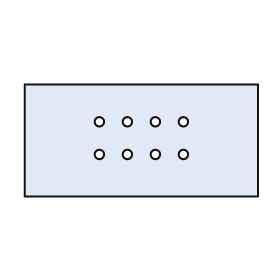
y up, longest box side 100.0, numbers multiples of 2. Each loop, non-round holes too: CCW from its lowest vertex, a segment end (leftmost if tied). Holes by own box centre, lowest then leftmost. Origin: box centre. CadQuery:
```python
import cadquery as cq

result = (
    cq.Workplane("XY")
    .moveTo(-50.0, -24.0)
    .lineTo(50.0, -24.0)
    .lineTo(50.0, 24.0)
    .lineTo(-50.0, 24.0)
    .close()
    .moveTo(-18.0, -6.0)
    .circle(2.0)
    .moveTo(-6.0, -6.0)
    .circle(2.0)
    .moveTo(6.0, -6.0)
    .circle(2.0)
    .moveTo(18.0, -6.0)
    .circle(2.0)
    .moveTo(-18.0, 8.0)
    .circle(2.0)
    .moveTo(-6.0, 8.0)
    .circle(2.0)
    .moveTo(6.0, 8.0)
    .circle(2.0)
    .moveTo(18.0, 8.0)
    .circle(2.0)
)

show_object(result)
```